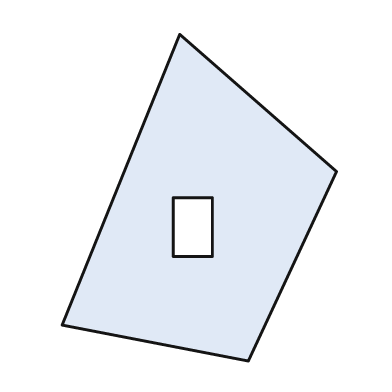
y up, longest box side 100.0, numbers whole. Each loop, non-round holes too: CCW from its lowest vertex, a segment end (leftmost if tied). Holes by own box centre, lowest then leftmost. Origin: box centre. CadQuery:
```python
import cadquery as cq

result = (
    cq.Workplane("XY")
    .moveTo(15.0, -50.0)
    .lineTo(42.0, 8.0)
    .lineTo(-6.0, 50.0)
    .lineTo(-42.0, -39.0)
    .close()
    .moveTo(-8.0, -18.0)
    .lineTo(4.0, -18.0)
    .lineTo(4.0, 0.0)
    .lineTo(-8.0, 0.0)
    .close()
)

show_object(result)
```